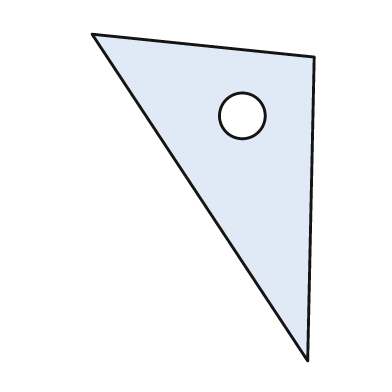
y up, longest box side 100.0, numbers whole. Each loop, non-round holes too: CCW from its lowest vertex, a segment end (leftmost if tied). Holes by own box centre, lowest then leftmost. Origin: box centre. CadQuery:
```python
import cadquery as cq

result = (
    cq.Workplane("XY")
    .moveTo(32.0, -50.0)
    .lineTo(34.0, 43.0)
    .lineTo(-34.0, 50.0)
    .close()
    .moveTo(12.0, 25.0)
    .circle(7.0)
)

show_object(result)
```